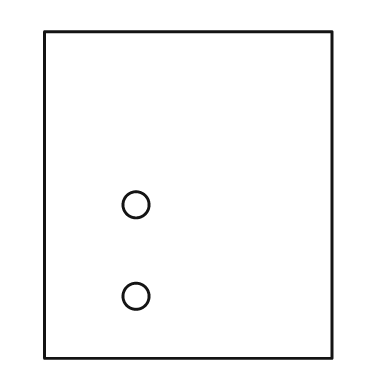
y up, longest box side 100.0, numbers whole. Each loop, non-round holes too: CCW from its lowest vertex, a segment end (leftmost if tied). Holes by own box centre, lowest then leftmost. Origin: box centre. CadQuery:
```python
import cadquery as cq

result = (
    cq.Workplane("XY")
    .moveTo(-44.0, -50.0)
    .lineTo(44.0, -50.0)
    .lineTo(44.0, 50.0)
    .lineTo(-44.0, 50.0)
    .close()
    .moveTo(-16.0, -31.0)
    .circle(4.0)
    .moveTo(-16.0, -3.0)
    .circle(4.0)
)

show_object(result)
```